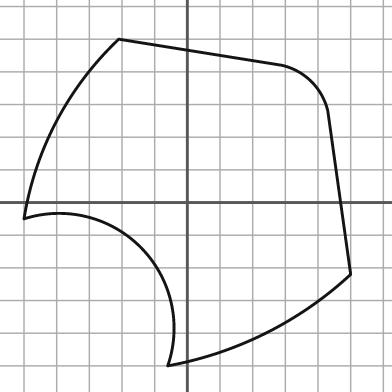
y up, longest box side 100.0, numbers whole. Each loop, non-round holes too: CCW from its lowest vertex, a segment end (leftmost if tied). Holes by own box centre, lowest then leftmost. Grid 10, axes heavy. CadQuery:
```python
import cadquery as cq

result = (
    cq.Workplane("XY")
    .moveTo(-6.0, -50.0)
    .threePointArc((24.0, -40.0), (50.0, -22.0))
    .lineTo(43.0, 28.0)
    .threePointArc((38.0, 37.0), (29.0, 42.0))
    .lineTo(-21.0, 50.0)
    .threePointArc((-40.0, 25.0), (-50.0, -5.0))
    .threePointArc((-14.0, -14.0), (-6.0, -50.0))
    .close()
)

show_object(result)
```